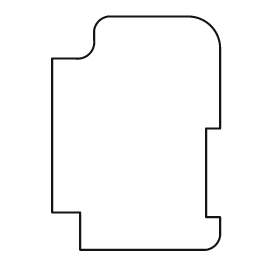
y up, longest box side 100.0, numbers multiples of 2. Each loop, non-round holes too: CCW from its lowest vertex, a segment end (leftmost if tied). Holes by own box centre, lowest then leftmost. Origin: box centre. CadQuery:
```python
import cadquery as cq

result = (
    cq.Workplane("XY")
    .moveTo(-24.0, -50.0)
    .lineTo(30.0, -50.0)
    .threePointArc((34.0, -48.0), (36.0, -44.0))
    .lineTo(36.0, -36.0)
    .lineTo(30.0, -36.0)
    .lineTo(30.0, 2.0)
    .lineTo(36.0, 2.0)
    .lineTo(36.0, 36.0)
    .threePointArc((32.0, 46.0), (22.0, 50.0))
    .lineTo(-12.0, 50.0)
    .threePointArc((-16.0, 48.0), (-18.0, 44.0))
    .lineTo(-18.0, 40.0)
    .threePointArc((-20.0, 34.0), (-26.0, 32.0))
    .lineTo(-36.0, 32.0)
    .lineTo(-36.0, -34.0)
    .lineTo(-24.0, -34.0)
    .close()
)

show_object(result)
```